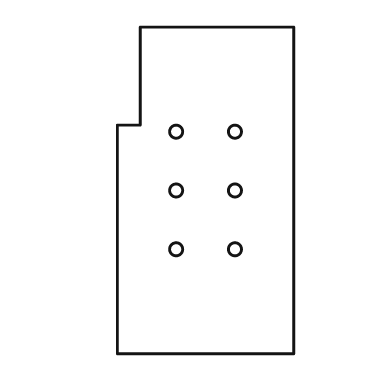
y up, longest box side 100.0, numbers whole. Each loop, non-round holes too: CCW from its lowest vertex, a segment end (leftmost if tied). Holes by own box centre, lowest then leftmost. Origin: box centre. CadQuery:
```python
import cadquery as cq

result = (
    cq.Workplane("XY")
    .moveTo(-27.0, -50.0)
    .lineTo(27.0, -50.0)
    .lineTo(27.0, 50.0)
    .lineTo(-20.0, 50.0)
    .lineTo(-20.0, 20.0)
    .lineTo(-27.0, 20.0)
    .close()
    .moveTo(-9.0, -18.0)
    .circle(2.0)
    .moveTo(9.0, -18.0)
    .circle(2.0)
    .moveTo(-9.0, 0.0)
    .circle(2.0)
    .moveTo(9.0, 0.0)
    .circle(2.0)
    .moveTo(-9.0, 18.0)
    .circle(2.0)
    .moveTo(9.0, 18.0)
    .circle(2.0)
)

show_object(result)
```